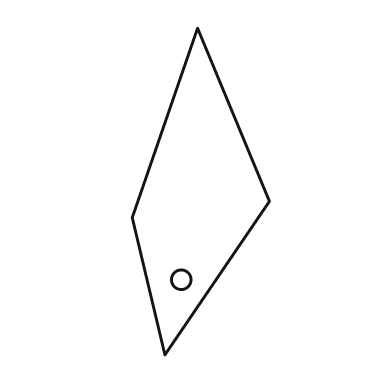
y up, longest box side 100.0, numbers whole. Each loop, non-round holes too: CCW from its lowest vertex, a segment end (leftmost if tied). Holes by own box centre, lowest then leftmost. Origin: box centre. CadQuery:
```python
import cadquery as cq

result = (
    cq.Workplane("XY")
    .moveTo(-11.0, -50.0)
    .lineTo(21.0, -3.0)
    .lineTo(-1.0, 50.0)
    .lineTo(-21.0, -8.0)
    .close()
    .moveTo(-6.0, -27.0)
    .circle(3.0)
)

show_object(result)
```